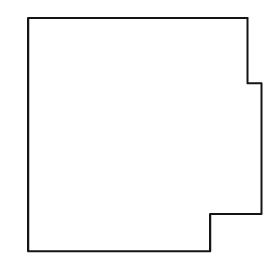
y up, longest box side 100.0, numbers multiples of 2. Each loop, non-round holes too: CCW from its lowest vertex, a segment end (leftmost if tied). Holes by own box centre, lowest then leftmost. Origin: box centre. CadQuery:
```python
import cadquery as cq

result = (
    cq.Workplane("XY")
    .moveTo(-50.0, -50.0)
    .lineTo(28.0, -50.0)
    .lineTo(28.0, -34.0)
    .lineTo(50.0, -34.0)
    .lineTo(50.0, 22.0)
    .lineTo(44.0, 22.0)
    .lineTo(44.0, 50.0)
    .lineTo(-50.0, 50.0)
    .close()
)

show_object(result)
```